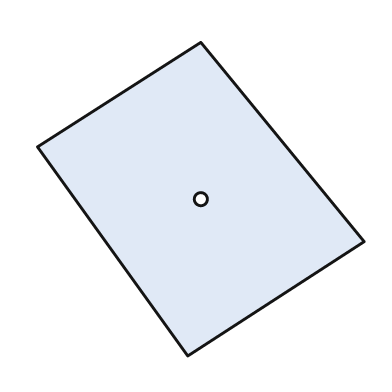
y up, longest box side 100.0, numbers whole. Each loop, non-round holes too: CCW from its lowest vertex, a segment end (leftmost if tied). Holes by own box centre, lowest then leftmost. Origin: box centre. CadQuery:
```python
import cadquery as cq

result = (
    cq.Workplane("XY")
    .moveTo(-4.0, -48.0)
    .lineTo(50.0, -13.0)
    .lineTo(0.0, 48.0)
    .lineTo(-50.0, 16.0)
    .close()
    .moveTo(0.0, 0.0)
    .circle(2.0)
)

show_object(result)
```